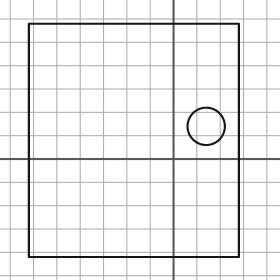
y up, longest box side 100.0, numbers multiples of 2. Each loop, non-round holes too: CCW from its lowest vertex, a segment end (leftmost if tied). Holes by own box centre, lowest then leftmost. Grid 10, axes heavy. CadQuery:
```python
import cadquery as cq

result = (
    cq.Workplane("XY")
    .moveTo(-62.0, -42.0)
    .lineTo(28.0, -42.0)
    .lineTo(28.0, 58.0)
    .lineTo(-62.0, 58.0)
    .close()
    .moveTo(14.0, 14.0)
    .circle(8.0)
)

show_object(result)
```